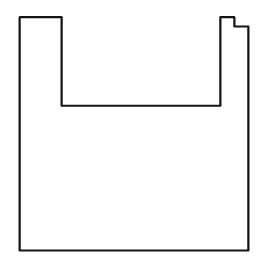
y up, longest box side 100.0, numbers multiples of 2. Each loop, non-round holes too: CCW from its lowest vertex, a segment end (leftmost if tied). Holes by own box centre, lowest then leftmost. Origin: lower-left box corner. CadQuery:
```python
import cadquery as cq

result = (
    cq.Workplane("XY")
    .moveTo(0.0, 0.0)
    .lineTo(98.0, 0.0)
    .lineTo(98.0, 96.0)
    .lineTo(92.0, 96.0)
    .lineTo(92.0, 100.0)
    .lineTo(86.0, 100.0)
    .lineTo(86.0, 62.0)
    .lineTo(18.0, 62.0)
    .lineTo(18.0, 100.0)
    .lineTo(0.0, 100.0)
    .close()
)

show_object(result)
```